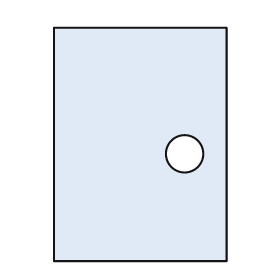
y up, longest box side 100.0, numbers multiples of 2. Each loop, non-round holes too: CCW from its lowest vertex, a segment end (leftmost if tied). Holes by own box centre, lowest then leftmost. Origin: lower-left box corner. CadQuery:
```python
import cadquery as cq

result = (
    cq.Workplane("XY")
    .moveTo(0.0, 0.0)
    .lineTo(74.0, 0.0)
    .lineTo(74.0, 100.0)
    .lineTo(0.0, 100.0)
    .close()
    .moveTo(56.0, 46.0)
    .circle(8.0)
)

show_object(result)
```